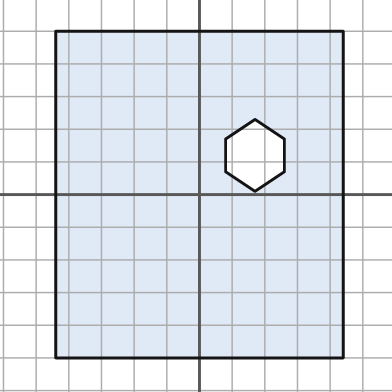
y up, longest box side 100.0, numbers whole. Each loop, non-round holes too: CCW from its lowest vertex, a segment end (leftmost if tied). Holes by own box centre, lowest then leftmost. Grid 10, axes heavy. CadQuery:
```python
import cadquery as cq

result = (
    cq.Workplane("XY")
    .moveTo(-44.0, -50.0)
    .lineTo(44.0, -50.0)
    .lineTo(44.0, 50.0)
    .lineTo(-44.0, 50.0)
    .close()
    .moveTo(17.0, 1.0)
    .lineTo(26.0, 7.0)
    .lineTo(26.0, 17.0)
    .lineTo(17.0, 23.0)
    .lineTo(8.0, 17.0)
    .lineTo(8.0, 7.0)
    .close()
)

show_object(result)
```